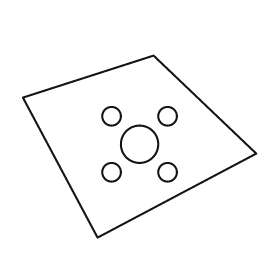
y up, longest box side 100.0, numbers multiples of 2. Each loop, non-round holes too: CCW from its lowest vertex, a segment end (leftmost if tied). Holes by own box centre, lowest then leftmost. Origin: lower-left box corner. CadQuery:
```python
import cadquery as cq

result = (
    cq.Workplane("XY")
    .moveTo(32.0, 0.0)
    .lineTo(100.0, 36.0)
    .lineTo(56.0, 78.0)
    .lineTo(0.0, 60.0)
    .close()
    .moveTo(38.0, 28.0)
    .circle(4.0)
    .moveTo(62.0, 28.0)
    .circle(4.0)
    .moveTo(50.0, 40.0)
    .circle(8.0)
    .moveTo(38.0, 52.0)
    .circle(4.0)
    .moveTo(62.0, 52.0)
    .circle(4.0)
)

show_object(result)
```